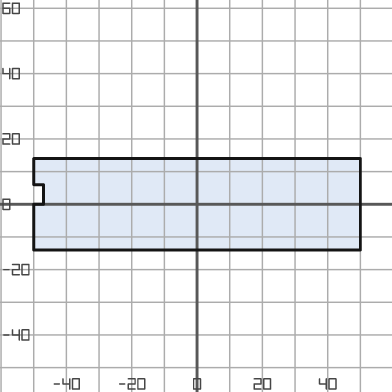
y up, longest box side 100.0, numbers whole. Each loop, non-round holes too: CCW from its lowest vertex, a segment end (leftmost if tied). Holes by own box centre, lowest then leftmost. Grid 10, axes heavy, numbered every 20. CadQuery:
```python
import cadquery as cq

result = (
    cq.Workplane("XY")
    .moveTo(-50.0, -14.0)
    .lineTo(50.0, -14.0)
    .lineTo(50.0, 14.0)
    .lineTo(-50.0, 14.0)
    .lineTo(-50.0, 6.0)
    .lineTo(-47.0, 6.0)
    .lineTo(-47.0, 0.0)
    .lineTo(-50.0, 0.0)
    .close()
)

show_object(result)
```